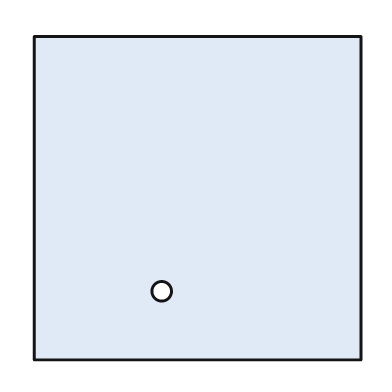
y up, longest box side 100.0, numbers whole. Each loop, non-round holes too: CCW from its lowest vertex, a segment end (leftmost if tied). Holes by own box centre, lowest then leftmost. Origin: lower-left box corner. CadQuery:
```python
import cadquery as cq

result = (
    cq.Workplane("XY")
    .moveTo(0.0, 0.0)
    .lineTo(100.0, 0.0)
    .lineTo(100.0, 99.0)
    .lineTo(0.0, 99.0)
    .close()
    .moveTo(39.0, 21.0)
    .circle(3.0)
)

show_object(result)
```